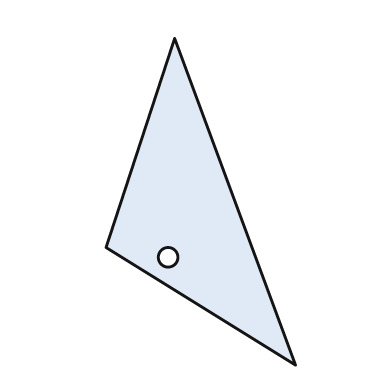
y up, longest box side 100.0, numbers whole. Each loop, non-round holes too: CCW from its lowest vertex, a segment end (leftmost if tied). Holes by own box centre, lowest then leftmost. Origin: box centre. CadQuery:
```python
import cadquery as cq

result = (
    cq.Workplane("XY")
    .moveTo(29.0, -50.0)
    .lineTo(-8.0, 50.0)
    .lineTo(-29.0, -14.0)
    .close()
    .moveTo(-10.0, -17.0)
    .circle(3.0)
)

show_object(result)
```